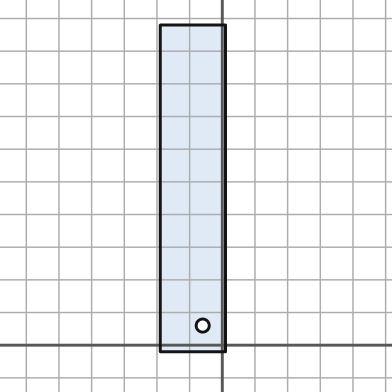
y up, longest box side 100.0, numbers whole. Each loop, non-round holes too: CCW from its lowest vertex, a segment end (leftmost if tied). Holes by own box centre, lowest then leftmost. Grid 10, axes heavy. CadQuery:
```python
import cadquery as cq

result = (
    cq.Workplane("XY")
    .moveTo(-19.0, -2.0)
    .lineTo(1.0, -2.0)
    .lineTo(1.0, 98.0)
    .lineTo(-19.0, 98.0)
    .close()
    .moveTo(-6.0, 6.0)
    .circle(2.0)
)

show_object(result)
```